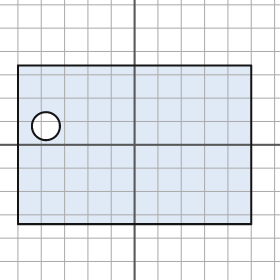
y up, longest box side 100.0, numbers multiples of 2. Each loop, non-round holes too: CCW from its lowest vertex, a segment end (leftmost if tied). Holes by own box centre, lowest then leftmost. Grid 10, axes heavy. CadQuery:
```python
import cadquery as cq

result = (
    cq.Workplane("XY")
    .moveTo(-50.0, -34.0)
    .lineTo(50.0, -34.0)
    .lineTo(50.0, 34.0)
    .lineTo(-50.0, 34.0)
    .close()
    .moveTo(-38.0, 8.0)
    .circle(6.0)
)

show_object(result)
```